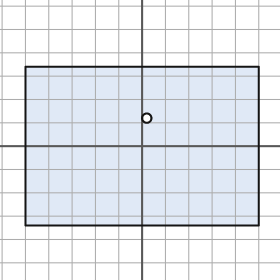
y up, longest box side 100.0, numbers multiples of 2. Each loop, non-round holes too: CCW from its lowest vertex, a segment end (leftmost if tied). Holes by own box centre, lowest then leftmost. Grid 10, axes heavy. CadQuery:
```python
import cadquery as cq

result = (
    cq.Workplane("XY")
    .moveTo(-50.0, -34.0)
    .lineTo(50.0, -34.0)
    .lineTo(50.0, 34.0)
    .lineTo(-50.0, 34.0)
    .close()
    .moveTo(2.0, 12.0)
    .circle(2.0)
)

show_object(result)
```